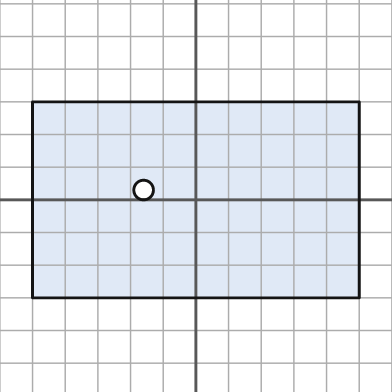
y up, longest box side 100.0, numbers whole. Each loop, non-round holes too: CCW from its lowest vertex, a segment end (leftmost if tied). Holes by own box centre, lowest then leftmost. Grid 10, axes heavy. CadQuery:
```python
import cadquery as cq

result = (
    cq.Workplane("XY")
    .moveTo(-50.0, -30.0)
    .lineTo(50.0, -30.0)
    .lineTo(50.0, 30.0)
    .lineTo(-50.0, 30.0)
    .close()
    .moveTo(-16.0, 3.0)
    .circle(3.0)
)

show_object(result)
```